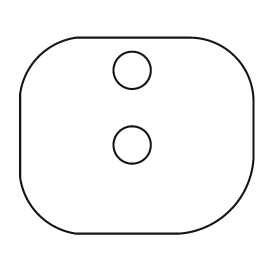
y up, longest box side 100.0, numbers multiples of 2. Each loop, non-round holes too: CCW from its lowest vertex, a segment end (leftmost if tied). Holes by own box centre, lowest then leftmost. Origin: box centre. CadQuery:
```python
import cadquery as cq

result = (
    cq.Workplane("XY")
    .moveTo(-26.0, -42.0)
    .lineTo(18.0, -42.0)
    .threePointArc((40.0, -32.0), (50.0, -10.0))
    .lineTo(50.0, 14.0)
    .threePointArc((42.0, 34.0), (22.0, 42.0))
    .lineTo(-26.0, 42.0)
    .threePointArc((-42.0, 34.0), (-50.0, 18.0))
    .lineTo(-50.0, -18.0)
    .threePointArc((-42.0, -34.0), (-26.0, -42.0))
    .close()
    .moveTo(-2.0, -4.0)
    .circle(8.0)
    .moveTo(-2.0, 28.0)
    .circle(8.0)
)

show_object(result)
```